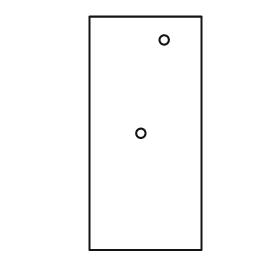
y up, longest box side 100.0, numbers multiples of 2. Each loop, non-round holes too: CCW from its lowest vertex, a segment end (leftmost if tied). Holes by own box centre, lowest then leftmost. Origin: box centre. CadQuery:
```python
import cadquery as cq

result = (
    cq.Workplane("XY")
    .moveTo(-24.0, -50.0)
    .lineTo(24.0, -50.0)
    .lineTo(24.0, 50.0)
    .lineTo(-24.0, 50.0)
    .close()
    .moveTo(-2.0, 0.0)
    .circle(2.0)
    .moveTo(8.0, 40.0)
    .circle(2.0)
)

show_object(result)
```